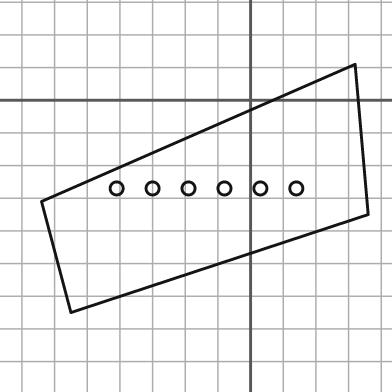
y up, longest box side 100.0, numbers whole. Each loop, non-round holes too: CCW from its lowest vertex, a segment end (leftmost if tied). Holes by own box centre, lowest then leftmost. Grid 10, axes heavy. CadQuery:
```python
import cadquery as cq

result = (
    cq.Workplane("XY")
    .moveTo(-55.0, -65.0)
    .lineTo(36.0, -35.0)
    .lineTo(32.0, 11.0)
    .lineTo(-64.0, -31.0)
    .close()
    .moveTo(-41.0, -27.0)
    .circle(2.0)
    .moveTo(-30.0, -27.0)
    .circle(2.0)
    .moveTo(-19.0, -27.0)
    .circle(2.0)
    .moveTo(-8.0, -27.0)
    .circle(2.0)
    .moveTo(3.0, -27.0)
    .circle(2.0)
    .moveTo(14.0, -27.0)
    .circle(2.0)
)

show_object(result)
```